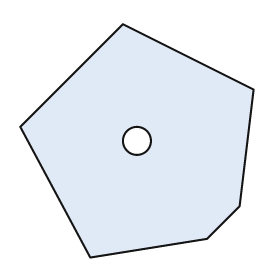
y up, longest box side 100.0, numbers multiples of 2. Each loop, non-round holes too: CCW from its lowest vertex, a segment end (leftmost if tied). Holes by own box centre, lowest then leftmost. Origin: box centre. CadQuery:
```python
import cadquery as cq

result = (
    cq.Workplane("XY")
    .moveTo(-20.0, -50.0)
    .lineTo(30.0, -42.0)
    .lineTo(44.0, -28.0)
    .lineTo(50.0, 22.0)
    .lineTo(-6.0, 50.0)
    .lineTo(-50.0, 6.0)
    .close()
    .moveTo(0.0, 0.0)
    .circle(6.0)
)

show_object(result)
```